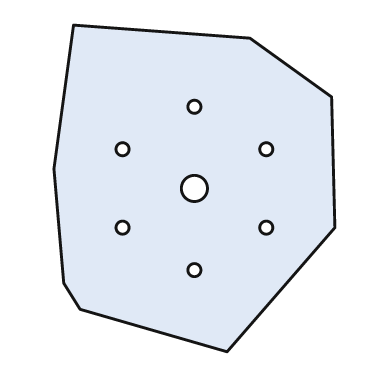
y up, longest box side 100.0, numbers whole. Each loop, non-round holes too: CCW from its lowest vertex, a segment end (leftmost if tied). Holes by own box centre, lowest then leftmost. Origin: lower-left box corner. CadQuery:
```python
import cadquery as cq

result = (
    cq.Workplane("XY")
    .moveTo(53.0, 0.0)
    .lineTo(86.0, 38.0)
    .lineTo(85.0, 78.0)
    .lineTo(60.0, 96.0)
    .lineTo(6.0, 100.0)
    .lineTo(0.0, 56.0)
    .lineTo(3.0, 21.0)
    .lineTo(8.0, 13.0)
    .close()
    .moveTo(43.0, 25.0)
    .circle(2.0)
    .moveTo(21.0, 38.0)
    .circle(2.0)
    .moveTo(65.0, 38.0)
    .circle(2.0)
    .moveTo(43.0, 50.0)
    .circle(4.0)
    .moveTo(21.0, 62.0)
    .circle(2.0)
    .moveTo(65.0, 62.0)
    .circle(2.0)
    .moveTo(43.0, 75.0)
    .circle(2.0)
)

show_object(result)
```